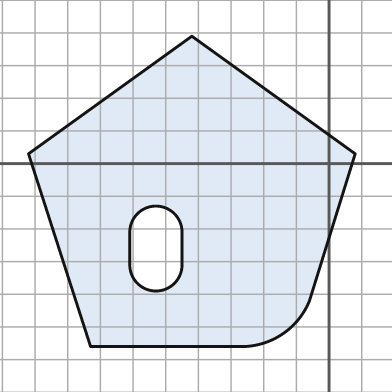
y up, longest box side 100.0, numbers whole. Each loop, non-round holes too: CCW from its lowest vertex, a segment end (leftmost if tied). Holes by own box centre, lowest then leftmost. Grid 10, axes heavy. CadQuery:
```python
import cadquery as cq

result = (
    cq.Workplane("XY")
    .moveTo(-73.0, -56.0)
    .lineTo(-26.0, -56.0)
    .threePointArc((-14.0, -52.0), (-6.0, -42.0))
    .lineTo(8.0, 3.0)
    .lineTo(-42.0, 39.0)
    .lineTo(-92.0, 3.0)
    .close()
    .moveTo(-61.0, -31.0)
    .threePointArc((-53.0, -39.0), (-45.0, -31.0))
    .lineTo(-45.0, -21.0)
    .threePointArc((-53.0, -13.0), (-61.0, -21.0))
    .close()
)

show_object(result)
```